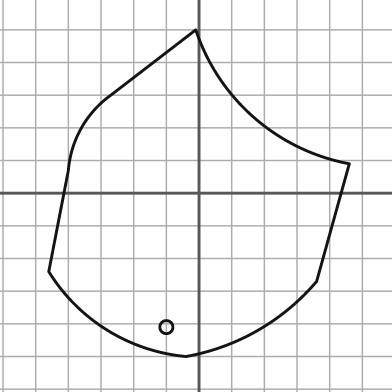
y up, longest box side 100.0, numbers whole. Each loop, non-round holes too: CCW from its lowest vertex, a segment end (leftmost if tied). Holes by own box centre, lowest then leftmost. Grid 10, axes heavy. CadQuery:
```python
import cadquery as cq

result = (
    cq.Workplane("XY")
    .moveTo(-4.0, -50.0)
    .threePointArc((18.0, -42.0), (36.0, -27.0))
    .lineTo(46.0, 9.0)
    .threePointArc((17.0, 23.0), (-1.0, 50.0))
    .lineTo(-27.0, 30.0)
    .threePointArc((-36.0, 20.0), (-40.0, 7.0))
    .lineTo(-46.0, -24.0)
    .threePointArc((-28.0, -42.0), (-4.0, -50.0))
    .close()
    .moveTo(-10.0, -41.0)
    .circle(2.0)
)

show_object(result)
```